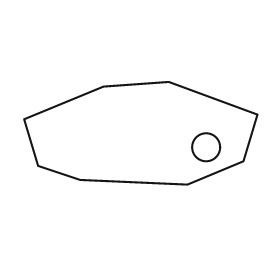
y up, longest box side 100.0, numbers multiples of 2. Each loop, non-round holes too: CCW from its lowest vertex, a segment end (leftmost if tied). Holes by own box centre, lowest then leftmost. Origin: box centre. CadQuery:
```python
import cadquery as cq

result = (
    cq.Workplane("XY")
    .moveTo(20.0, -22.0)
    .lineTo(44.0, -12.0)
    .lineTo(50.0, 8.0)
    .lineTo(12.0, 22.0)
    .lineTo(-16.0, 20.0)
    .lineTo(-50.0, 6.0)
    .lineTo(-44.0, -14.0)
    .lineTo(-26.0, -20.0)
    .close()
    .moveTo(28.0, -6.0)
    .circle(6.0)
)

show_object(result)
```